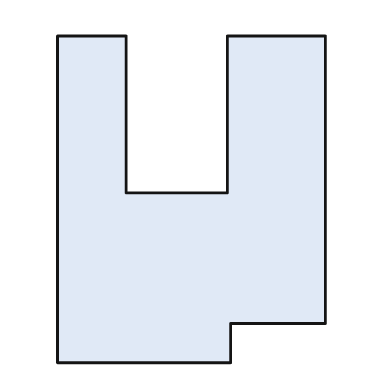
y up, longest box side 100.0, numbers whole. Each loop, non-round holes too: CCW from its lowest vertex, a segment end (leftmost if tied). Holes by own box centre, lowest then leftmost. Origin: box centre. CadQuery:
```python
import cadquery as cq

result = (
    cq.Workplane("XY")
    .moveTo(-41.0, -50.0)
    .lineTo(12.0, -50.0)
    .lineTo(12.0, -38.0)
    .lineTo(41.0, -38.0)
    .lineTo(41.0, 50.0)
    .lineTo(11.0, 50.0)
    .lineTo(11.0, 2.0)
    .lineTo(-20.0, 2.0)
    .lineTo(-20.0, 50.0)
    .lineTo(-41.0, 50.0)
    .close()
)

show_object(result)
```